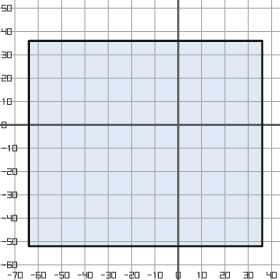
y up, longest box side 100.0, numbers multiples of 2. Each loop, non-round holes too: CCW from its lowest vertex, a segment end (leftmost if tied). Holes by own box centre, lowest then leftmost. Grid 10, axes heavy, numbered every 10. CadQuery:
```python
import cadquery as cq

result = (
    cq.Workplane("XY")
    .moveTo(-64.0, -52.0)
    .lineTo(36.0, -52.0)
    .lineTo(36.0, 36.0)
    .lineTo(-64.0, 36.0)
    .close()
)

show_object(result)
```